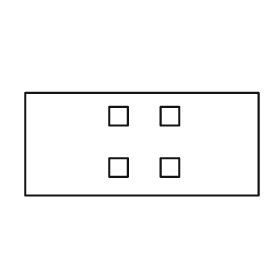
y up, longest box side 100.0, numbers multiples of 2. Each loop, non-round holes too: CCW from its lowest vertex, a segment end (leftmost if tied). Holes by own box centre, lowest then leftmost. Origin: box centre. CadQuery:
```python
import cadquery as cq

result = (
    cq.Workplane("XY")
    .moveTo(-50.0, -22.0)
    .lineTo(50.0, -22.0)
    .lineTo(50.0, 22.0)
    .lineTo(-50.0, 22.0)
    .close()
    .moveTo(-14.0, -14.0)
    .lineTo(-6.0, -14.0)
    .lineTo(-6.0, -6.0)
    .lineTo(-14.0, -6.0)
    .close()
    .moveTo(8.0, -14.0)
    .lineTo(16.0, -14.0)
    .lineTo(16.0, -6.0)
    .lineTo(8.0, -6.0)
    .close()
    .moveTo(-14.0, 8.0)
    .lineTo(-6.0, 8.0)
    .lineTo(-6.0, 16.0)
    .lineTo(-14.0, 16.0)
    .close()
    .moveTo(8.0, 8.0)
    .lineTo(16.0, 8.0)
    .lineTo(16.0, 16.0)
    .lineTo(8.0, 16.0)
    .close()
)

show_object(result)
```